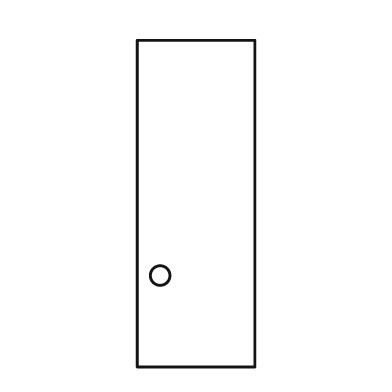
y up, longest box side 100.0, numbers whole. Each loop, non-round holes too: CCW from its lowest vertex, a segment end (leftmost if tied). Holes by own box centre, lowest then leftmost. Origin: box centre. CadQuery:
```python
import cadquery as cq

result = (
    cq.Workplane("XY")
    .moveTo(-18.0, -50.0)
    .lineTo(18.0, -50.0)
    .lineTo(18.0, 50.0)
    .lineTo(-18.0, 50.0)
    .close()
    .moveTo(-11.0, -22.0)
    .circle(3.0)
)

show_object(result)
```